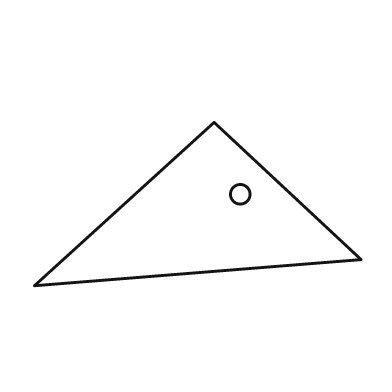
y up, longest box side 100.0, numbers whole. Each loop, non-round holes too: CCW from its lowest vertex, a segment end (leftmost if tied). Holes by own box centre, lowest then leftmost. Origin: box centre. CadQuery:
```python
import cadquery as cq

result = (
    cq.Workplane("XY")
    .moveTo(-50.0, -25.0)
    .lineTo(50.0, -17.0)
    .lineTo(5.0, 25.0)
    .close()
    .moveTo(13.0, 3.0)
    .circle(3.0)
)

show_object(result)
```